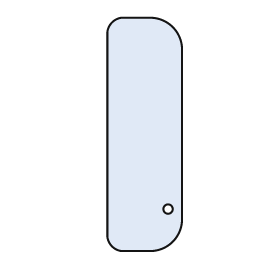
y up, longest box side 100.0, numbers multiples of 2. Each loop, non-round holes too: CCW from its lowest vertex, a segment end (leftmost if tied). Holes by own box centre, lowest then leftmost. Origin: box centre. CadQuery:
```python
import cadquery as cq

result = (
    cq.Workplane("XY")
    .moveTo(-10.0, -50.0)
    .lineTo(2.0, -50.0)
    .threePointArc((12.0, -46.0), (16.0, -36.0))
    .lineTo(16.0, 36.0)
    .threePointArc((12.0, 46.0), (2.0, 50.0))
    .lineTo(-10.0, 50.0)
    .threePointArc((-14.0, 48.0), (-16.0, 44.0))
    .lineTo(-16.0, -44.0)
    .threePointArc((-14.0, -48.0), (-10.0, -50.0))
    .close()
    .moveTo(10.0, -32.0)
    .circle(2.0)
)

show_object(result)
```